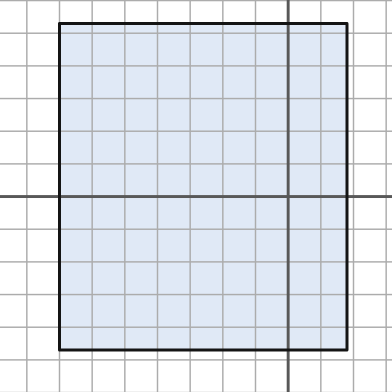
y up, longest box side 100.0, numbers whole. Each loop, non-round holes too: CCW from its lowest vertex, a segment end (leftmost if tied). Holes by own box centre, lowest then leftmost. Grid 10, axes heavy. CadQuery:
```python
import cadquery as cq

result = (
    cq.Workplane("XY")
    .moveTo(-70.0, -47.0)
    .lineTo(18.0, -47.0)
    .lineTo(18.0, 53.0)
    .lineTo(-70.0, 53.0)
    .close()
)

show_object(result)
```